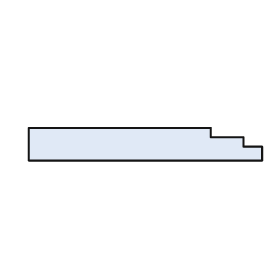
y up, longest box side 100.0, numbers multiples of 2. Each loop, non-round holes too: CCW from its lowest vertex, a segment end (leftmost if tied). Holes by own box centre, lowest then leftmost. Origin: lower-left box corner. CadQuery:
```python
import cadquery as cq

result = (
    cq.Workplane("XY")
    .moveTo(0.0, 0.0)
    .lineTo(100.0, 0.0)
    .lineTo(100.0, 6.0)
    .lineTo(92.0, 6.0)
    .lineTo(92.0, 10.0)
    .lineTo(78.0, 10.0)
    .lineTo(78.0, 14.0)
    .lineTo(0.0, 14.0)
    .close()
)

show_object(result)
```